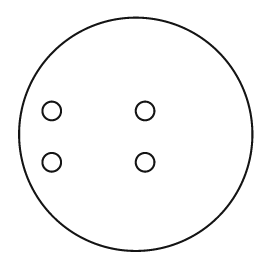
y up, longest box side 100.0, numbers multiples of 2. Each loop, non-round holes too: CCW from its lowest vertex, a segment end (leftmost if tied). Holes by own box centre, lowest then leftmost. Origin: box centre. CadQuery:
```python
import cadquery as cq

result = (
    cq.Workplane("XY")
    .moveTo(0.0, 0.0)
    .circle(50.0)
    .moveTo(-36.0, -12.0)
    .circle(4.0)
    .moveTo(4.0, -12.0)
    .circle(4.0)
    .moveTo(-36.0, 10.0)
    .circle(4.0)
    .moveTo(4.0, 10.0)
    .circle(4.0)
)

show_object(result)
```